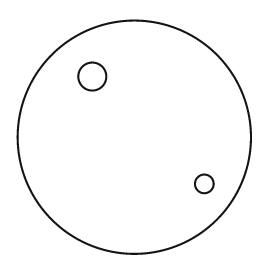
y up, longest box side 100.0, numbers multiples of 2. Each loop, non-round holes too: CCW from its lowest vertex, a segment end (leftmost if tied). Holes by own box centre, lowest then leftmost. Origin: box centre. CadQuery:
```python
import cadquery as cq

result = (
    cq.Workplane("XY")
    .moveTo(0.0, 0.0)
    .circle(50.0)
    .moveTo(30.0, -20.0)
    .circle(4.0)
    .moveTo(-18.0, 26.0)
    .circle(6.0)
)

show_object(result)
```